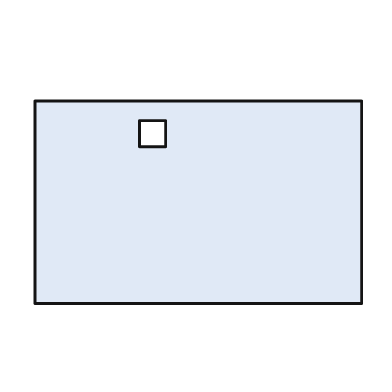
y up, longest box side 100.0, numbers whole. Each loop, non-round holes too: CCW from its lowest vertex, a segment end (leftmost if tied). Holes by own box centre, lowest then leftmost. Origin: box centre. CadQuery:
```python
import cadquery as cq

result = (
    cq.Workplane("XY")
    .moveTo(-50.0, -31.0)
    .lineTo(50.0, -31.0)
    .lineTo(50.0, 31.0)
    .lineTo(-50.0, 31.0)
    .close()
    .moveTo(-18.0, 17.0)
    .lineTo(-10.0, 17.0)
    .lineTo(-10.0, 25.0)
    .lineTo(-18.0, 25.0)
    .close()
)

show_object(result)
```